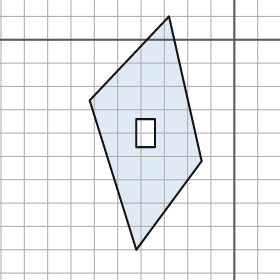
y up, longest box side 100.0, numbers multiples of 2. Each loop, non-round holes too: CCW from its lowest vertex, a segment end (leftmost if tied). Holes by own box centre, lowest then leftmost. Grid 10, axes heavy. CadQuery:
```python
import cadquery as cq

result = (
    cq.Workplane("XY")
    .moveTo(-42.0, -90.0)
    .lineTo(-14.0, -52.0)
    .lineTo(-28.0, 10.0)
    .lineTo(-62.0, -26.0)
    .close()
    .moveTo(-42.0, -46.0)
    .lineTo(-34.0, -46.0)
    .lineTo(-34.0, -34.0)
    .lineTo(-42.0, -34.0)
    .close()
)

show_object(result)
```